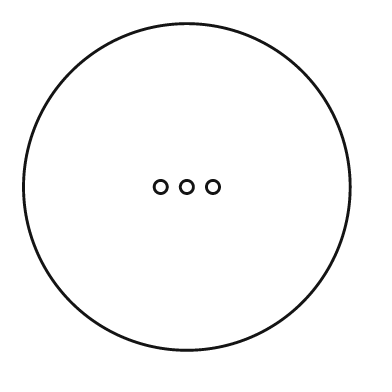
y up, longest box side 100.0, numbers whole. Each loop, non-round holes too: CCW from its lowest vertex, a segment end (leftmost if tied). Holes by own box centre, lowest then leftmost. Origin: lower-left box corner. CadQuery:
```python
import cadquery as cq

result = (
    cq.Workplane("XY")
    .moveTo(50.0, 50.0)
    .circle(50.0)
    .moveTo(42.0, 50.0)
    .circle(2.0)
    .moveTo(50.0, 50.0)
    .circle(2.0)
    .moveTo(58.0, 50.0)
    .circle(2.0)
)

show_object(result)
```